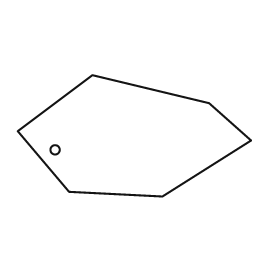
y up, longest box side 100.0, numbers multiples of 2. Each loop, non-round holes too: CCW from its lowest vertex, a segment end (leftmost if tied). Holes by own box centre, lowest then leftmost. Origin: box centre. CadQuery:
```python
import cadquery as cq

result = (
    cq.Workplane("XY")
    .moveTo(12.0, -26.0)
    .lineTo(50.0, -2.0)
    .lineTo(32.0, 14.0)
    .lineTo(-18.0, 26.0)
    .lineTo(-50.0, 2.0)
    .lineTo(-28.0, -24.0)
    .close()
    .moveTo(-34.0, -6.0)
    .circle(2.0)
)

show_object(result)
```